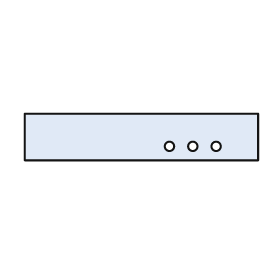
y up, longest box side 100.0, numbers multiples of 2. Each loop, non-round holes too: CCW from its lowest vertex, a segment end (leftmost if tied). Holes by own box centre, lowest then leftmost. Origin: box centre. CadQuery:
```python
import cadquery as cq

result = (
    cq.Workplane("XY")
    .moveTo(-50.0, -10.0)
    .lineTo(50.0, -10.0)
    .lineTo(50.0, 10.0)
    .lineTo(-50.0, 10.0)
    .close()
    .moveTo(12.0, -4.0)
    .circle(2.0)
    .moveTo(22.0, -4.0)
    .circle(2.0)
    .moveTo(32.0, -4.0)
    .circle(2.0)
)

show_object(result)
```